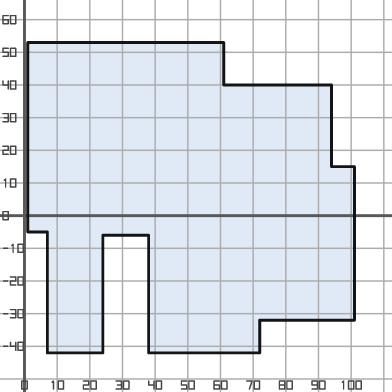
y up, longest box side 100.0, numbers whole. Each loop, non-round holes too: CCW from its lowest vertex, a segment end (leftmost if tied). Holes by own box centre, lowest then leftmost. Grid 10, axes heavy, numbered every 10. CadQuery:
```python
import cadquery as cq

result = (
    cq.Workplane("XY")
    .moveTo(7.0, -42.0)
    .lineTo(24.0, -42.0)
    .lineTo(24.0, -6.0)
    .lineTo(38.0, -6.0)
    .lineTo(38.0, -42.0)
    .lineTo(72.0, -42.0)
    .lineTo(72.0, -32.0)
    .lineTo(101.0, -32.0)
    .lineTo(101.0, 15.0)
    .lineTo(94.0, 15.0)
    .lineTo(94.0, 40.0)
    .lineTo(61.0, 40.0)
    .lineTo(61.0, 53.0)
    .lineTo(1.0, 53.0)
    .lineTo(1.0, -5.0)
    .lineTo(7.0, -5.0)
    .close()
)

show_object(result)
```